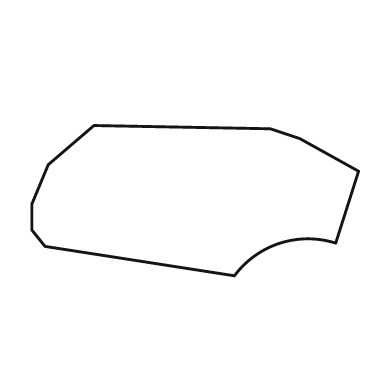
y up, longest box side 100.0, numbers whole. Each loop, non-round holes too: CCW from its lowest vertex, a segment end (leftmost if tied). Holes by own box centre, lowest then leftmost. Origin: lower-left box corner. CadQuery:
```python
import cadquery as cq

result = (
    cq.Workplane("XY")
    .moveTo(62.0, 0.0)
    .threePointArc((76.0, 10.0), (93.0, 10.0))
    .lineTo(100.0, 32.0)
    .lineTo(82.0, 42.0)
    .lineTo(73.0, 45.0)
    .lineTo(19.0, 46.0)
    .lineTo(5.0, 34.0)
    .lineTo(0.0, 22.0)
    .lineTo(0.0, 14.0)
    .lineTo(4.0, 9.0)
    .close()
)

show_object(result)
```